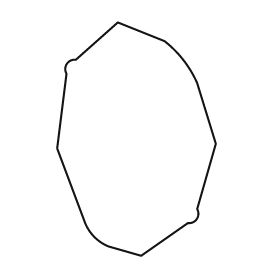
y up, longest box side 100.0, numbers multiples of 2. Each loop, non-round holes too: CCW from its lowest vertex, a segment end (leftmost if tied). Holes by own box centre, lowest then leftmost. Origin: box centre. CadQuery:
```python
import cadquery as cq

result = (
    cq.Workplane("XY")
    .moveTo(2.0, -50.0)
    .lineTo(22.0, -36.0)
    .threePointArc((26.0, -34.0), (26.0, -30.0))
    .lineTo(34.0, -2.0)
    .lineTo(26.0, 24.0)
    .threePointArc((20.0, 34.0), (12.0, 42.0))
    .lineTo(-8.0, 50.0)
    .lineTo(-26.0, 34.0)
    .threePointArc((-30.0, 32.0), (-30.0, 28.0))
    .lineTo(-34.0, -4.0)
    .lineTo(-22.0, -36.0)
    .threePointArc((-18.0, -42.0), (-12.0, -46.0))
    .close()
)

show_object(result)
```